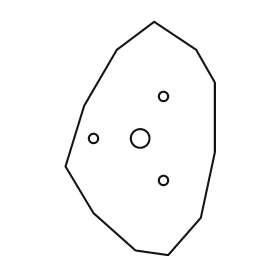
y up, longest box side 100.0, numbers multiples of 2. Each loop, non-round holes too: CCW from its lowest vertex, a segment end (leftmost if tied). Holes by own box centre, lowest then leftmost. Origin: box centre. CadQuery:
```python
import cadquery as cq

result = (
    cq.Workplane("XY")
    .moveTo(12.0, -50.0)
    .lineTo(26.0, -34.0)
    .lineTo(32.0, -6.0)
    .lineTo(32.0, 24.0)
    .lineTo(24.0, 38.0)
    .lineTo(6.0, 50.0)
    .lineTo(-10.0, 38.0)
    .lineTo(-24.0, 14.0)
    .lineTo(-32.0, -12.0)
    .lineTo(-20.0, -32.0)
    .lineTo(-2.0, -48.0)
    .close()
    .moveTo(10.0, -18.0)
    .circle(2.0)
    .moveTo(-20.0, 0.0)
    .circle(2.0)
    .moveTo(0.0, 0.0)
    .circle(4.0)
    .moveTo(10.0, 18.0)
    .circle(2.0)
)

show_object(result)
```